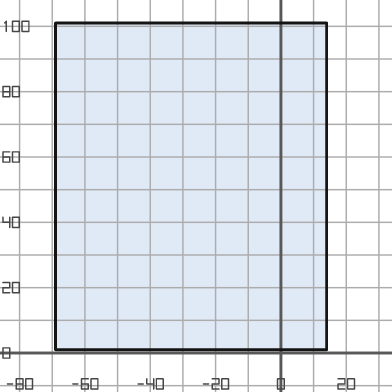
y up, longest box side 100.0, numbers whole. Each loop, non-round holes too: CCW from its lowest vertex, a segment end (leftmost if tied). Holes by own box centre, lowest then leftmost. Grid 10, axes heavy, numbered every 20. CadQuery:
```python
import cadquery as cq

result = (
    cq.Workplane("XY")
    .moveTo(-69.0, 1.0)
    .lineTo(14.0, 1.0)
    .lineTo(14.0, 101.0)
    .lineTo(-69.0, 101.0)
    .close()
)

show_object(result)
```